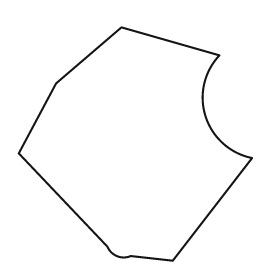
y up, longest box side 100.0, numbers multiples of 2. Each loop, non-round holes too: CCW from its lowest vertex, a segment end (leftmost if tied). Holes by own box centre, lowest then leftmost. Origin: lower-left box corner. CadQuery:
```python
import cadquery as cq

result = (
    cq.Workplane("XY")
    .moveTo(66.0, 0.0)
    .lineTo(100.0, 44.0)
    .threePointArc((80.0, 62.0), (86.0, 88.0))
    .lineTo(44.0, 100.0)
    .lineTo(16.0, 76.0)
    .lineTo(0.0, 46.0)
    .lineTo(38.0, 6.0)
    .threePointArc((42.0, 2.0), (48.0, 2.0))
    .close()
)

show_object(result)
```